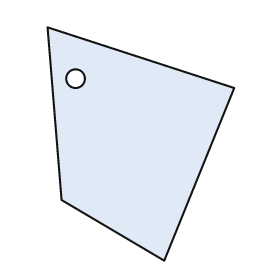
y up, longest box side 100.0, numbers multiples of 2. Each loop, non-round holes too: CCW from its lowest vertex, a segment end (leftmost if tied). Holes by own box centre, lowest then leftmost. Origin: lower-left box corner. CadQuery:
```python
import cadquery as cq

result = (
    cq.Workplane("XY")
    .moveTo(50.0, 0.0)
    .lineTo(80.0, 74.0)
    .lineTo(0.0, 100.0)
    .lineTo(6.0, 26.0)
    .close()
    .moveTo(12.0, 78.0)
    .circle(4.0)
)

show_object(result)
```